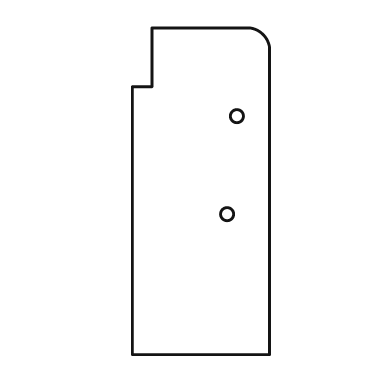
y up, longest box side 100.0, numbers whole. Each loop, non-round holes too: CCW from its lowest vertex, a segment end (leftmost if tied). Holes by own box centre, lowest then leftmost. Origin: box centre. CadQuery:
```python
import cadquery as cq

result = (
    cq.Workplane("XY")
    .moveTo(-21.0, -50.0)
    .lineTo(21.0, -50.0)
    .lineTo(21.0, 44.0)
    .threePointArc((19.0, 48.0), (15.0, 50.0))
    .lineTo(-15.0, 50.0)
    .lineTo(-15.0, 32.0)
    .lineTo(-21.0, 32.0)
    .close()
    .moveTo(8.0, -7.0)
    .circle(2.0)
    .moveTo(11.0, 23.0)
    .circle(2.0)
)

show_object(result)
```